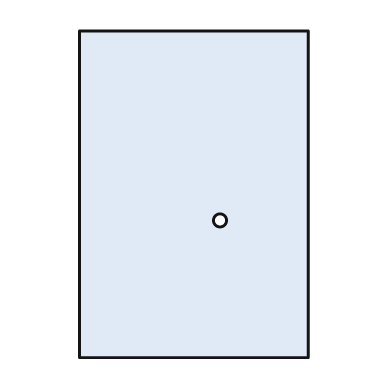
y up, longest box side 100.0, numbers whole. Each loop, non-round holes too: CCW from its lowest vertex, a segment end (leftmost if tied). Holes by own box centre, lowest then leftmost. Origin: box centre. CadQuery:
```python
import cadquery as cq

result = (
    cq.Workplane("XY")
    .moveTo(-35.0, -50.0)
    .lineTo(35.0, -50.0)
    .lineTo(35.0, 50.0)
    .lineTo(-35.0, 50.0)
    .close()
    .moveTo(8.0, -8.0)
    .circle(2.0)
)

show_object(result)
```